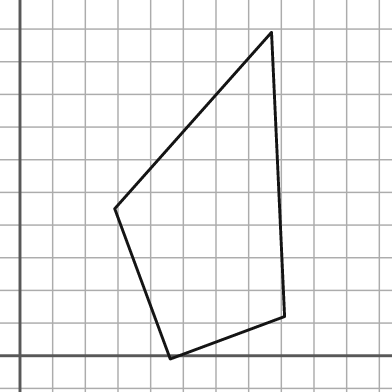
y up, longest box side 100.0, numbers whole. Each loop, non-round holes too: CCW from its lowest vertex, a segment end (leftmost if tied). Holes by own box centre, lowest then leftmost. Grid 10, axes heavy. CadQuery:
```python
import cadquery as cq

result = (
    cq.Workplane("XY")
    .moveTo(46.0, -1.0)
    .lineTo(81.0, 12.0)
    .lineTo(77.0, 99.0)
    .lineTo(29.0, 45.0)
    .close()
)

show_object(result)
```